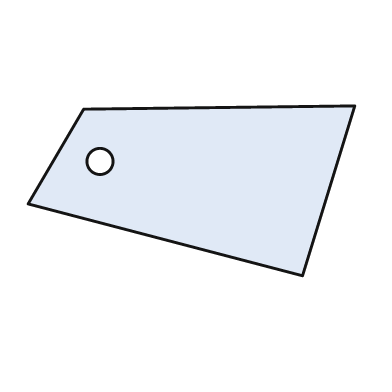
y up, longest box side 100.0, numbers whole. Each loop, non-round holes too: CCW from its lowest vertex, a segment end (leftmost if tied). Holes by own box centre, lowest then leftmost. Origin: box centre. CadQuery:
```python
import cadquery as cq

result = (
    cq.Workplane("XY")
    .moveTo(34.0, -26.0)
    .lineTo(50.0, 26.0)
    .lineTo(-33.0, 25.0)
    .lineTo(-50.0, -4.0)
    .close()
    .moveTo(-28.0, 9.0)
    .circle(4.0)
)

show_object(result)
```